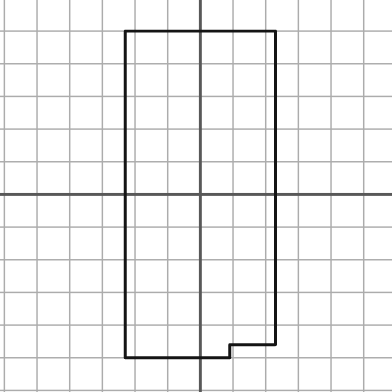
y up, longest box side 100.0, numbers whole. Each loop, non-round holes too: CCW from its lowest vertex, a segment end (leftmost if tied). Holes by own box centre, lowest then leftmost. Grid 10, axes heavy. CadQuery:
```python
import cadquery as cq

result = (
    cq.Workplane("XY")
    .moveTo(-23.0, -50.0)
    .lineTo(9.0, -50.0)
    .lineTo(9.0, -46.0)
    .lineTo(23.0, -46.0)
    .lineTo(23.0, 50.0)
    .lineTo(-23.0, 50.0)
    .close()
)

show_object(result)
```